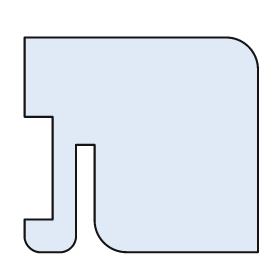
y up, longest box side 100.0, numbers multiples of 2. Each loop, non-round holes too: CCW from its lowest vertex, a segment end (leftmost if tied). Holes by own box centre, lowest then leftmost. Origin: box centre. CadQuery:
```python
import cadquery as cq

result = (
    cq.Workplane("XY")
    .moveTo(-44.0, -46.0)
    .lineTo(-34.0, -46.0)
    .threePointArc((-30.0, -44.0), (-28.0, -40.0))
    .lineTo(-28.0, 0.0)
    .lineTo(-20.0, 0.0)
    .lineTo(-20.0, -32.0)
    .threePointArc((-16.0, -42.0), (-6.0, -46.0))
    .lineTo(50.0, -46.0)
    .lineTo(50.0, 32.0)
    .threePointArc((46.0, 42.0), (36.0, 46.0))
    .lineTo(-50.0, 46.0)
    .lineTo(-50.0, 12.0)
    .lineTo(-38.0, 12.0)
    .lineTo(-38.0, -32.0)
    .lineTo(-50.0, -32.0)
    .lineTo(-50.0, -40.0)
    .threePointArc((-48.0, -44.0), (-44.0, -46.0))
    .close()
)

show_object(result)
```